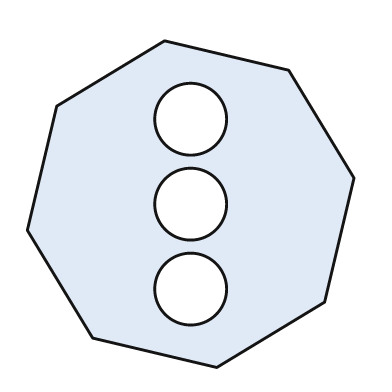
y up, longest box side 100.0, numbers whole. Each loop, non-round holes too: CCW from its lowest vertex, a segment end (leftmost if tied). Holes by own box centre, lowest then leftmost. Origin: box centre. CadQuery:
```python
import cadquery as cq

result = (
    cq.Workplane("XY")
    .moveTo(8.0, -50.0)
    .lineTo(41.0, -30.0)
    .lineTo(50.0, 8.0)
    .lineTo(30.0, 41.0)
    .lineTo(-8.0, 50.0)
    .lineTo(-41.0, 30.0)
    .lineTo(-50.0, -8.0)
    .lineTo(-30.0, -41.0)
    .close()
    .moveTo(0.0, -26.0)
    .circle(11.0)
    .moveTo(0.0, 0.0)
    .circle(11.0)
    .moveTo(0.0, 26.0)
    .circle(11.0)
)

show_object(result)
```